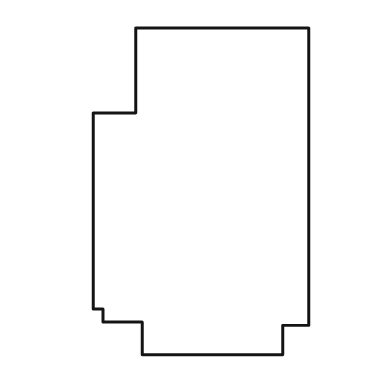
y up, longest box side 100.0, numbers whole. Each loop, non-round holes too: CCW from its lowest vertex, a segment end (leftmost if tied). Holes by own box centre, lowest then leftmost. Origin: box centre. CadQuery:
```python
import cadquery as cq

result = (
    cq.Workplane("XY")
    .moveTo(-18.0, -50.0)
    .lineTo(25.0, -50.0)
    .lineTo(25.0, -41.0)
    .lineTo(33.0, -41.0)
    .lineTo(33.0, 50.0)
    .lineTo(-20.0, 50.0)
    .lineTo(-20.0, 24.0)
    .lineTo(-33.0, 24.0)
    .lineTo(-33.0, -36.0)
    .lineTo(-30.0, -36.0)
    .lineTo(-30.0, -40.0)
    .lineTo(-18.0, -40.0)
    .close()
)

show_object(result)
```